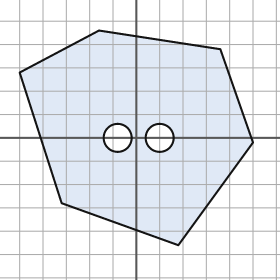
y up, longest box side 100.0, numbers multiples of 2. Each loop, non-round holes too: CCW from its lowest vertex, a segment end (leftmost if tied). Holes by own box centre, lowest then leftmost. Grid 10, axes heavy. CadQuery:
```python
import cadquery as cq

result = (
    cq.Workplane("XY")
    .moveTo(18.0, -46.0)
    .lineTo(50.0, -2.0)
    .lineTo(36.0, 38.0)
    .lineTo(-16.0, 46.0)
    .lineTo(-50.0, 28.0)
    .lineTo(-32.0, -28.0)
    .close()
    .moveTo(-8.0, 0.0)
    .circle(6.0)
    .moveTo(10.0, 0.0)
    .circle(6.0)
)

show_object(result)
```